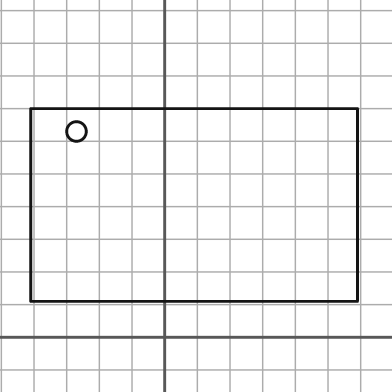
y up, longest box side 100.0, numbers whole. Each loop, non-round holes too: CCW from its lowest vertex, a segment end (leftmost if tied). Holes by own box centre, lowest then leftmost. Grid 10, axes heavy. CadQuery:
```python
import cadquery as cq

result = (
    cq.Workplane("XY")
    .moveTo(-41.0, 11.0)
    .lineTo(59.0, 11.0)
    .lineTo(59.0, 70.0)
    .lineTo(-41.0, 70.0)
    .close()
    .moveTo(-27.0, 63.0)
    .circle(3.0)
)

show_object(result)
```